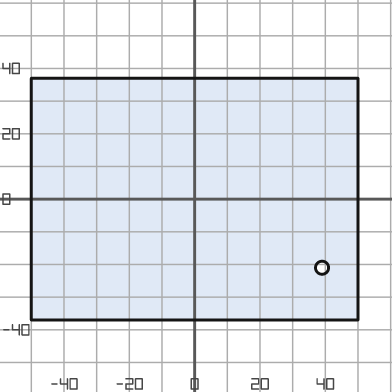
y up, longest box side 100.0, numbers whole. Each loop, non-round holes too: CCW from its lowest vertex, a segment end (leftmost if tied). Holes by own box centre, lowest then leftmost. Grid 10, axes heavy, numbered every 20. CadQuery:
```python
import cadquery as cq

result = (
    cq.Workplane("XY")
    .moveTo(-50.0, -37.0)
    .lineTo(50.0, -37.0)
    .lineTo(50.0, 37.0)
    .lineTo(-50.0, 37.0)
    .close()
    .moveTo(39.0, -21.0)
    .circle(2.0)
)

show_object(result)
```